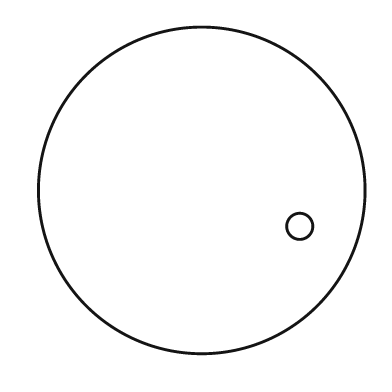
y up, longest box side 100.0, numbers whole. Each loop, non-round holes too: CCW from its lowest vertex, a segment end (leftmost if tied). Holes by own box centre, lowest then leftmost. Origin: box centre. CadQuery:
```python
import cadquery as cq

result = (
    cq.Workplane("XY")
    .moveTo(0.0, 0.0)
    .circle(50.0)
    .moveTo(30.0, -11.0)
    .circle(4.0)
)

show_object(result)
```